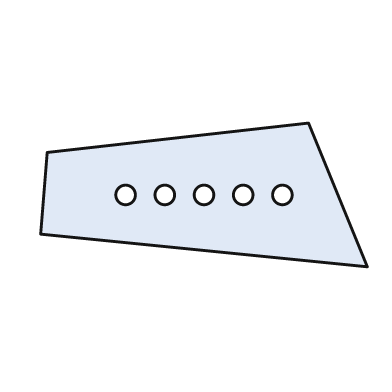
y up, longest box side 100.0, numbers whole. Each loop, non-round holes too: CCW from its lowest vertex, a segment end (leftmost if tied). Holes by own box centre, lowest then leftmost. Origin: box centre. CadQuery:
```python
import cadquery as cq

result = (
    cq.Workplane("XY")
    .moveTo(50.0, -22.0)
    .lineTo(32.0, 22.0)
    .lineTo(-48.0, 13.0)
    .lineTo(-50.0, -12.0)
    .close()
    .moveTo(-24.0, 0.0)
    .circle(3.0)
    .moveTo(-12.0, 0.0)
    .circle(3.0)
    .moveTo(0.0, 0.0)
    .circle(3.0)
    .moveTo(12.0, 0.0)
    .circle(3.0)
    .moveTo(24.0, 0.0)
    .circle(3.0)
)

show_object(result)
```